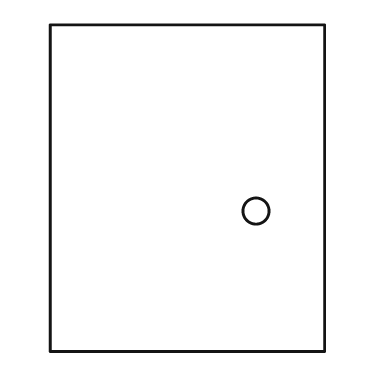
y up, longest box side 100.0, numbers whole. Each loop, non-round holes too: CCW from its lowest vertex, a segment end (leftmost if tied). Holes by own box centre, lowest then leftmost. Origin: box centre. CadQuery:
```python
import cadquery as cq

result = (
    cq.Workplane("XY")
    .moveTo(-42.0, -50.0)
    .lineTo(42.0, -50.0)
    .lineTo(42.0, 50.0)
    .lineTo(-42.0, 50.0)
    .close()
    .moveTo(21.0, -7.0)
    .circle(4.0)
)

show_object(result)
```